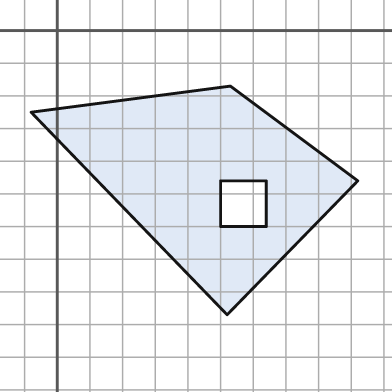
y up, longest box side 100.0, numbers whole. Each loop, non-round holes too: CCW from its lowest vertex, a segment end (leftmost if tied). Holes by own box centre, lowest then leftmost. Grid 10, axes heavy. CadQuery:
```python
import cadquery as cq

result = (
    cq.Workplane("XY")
    .moveTo(52.0, -87.0)
    .lineTo(92.0, -46.0)
    .lineTo(53.0, -17.0)
    .lineTo(-8.0, -25.0)
    .close()
    .moveTo(50.0, -60.0)
    .lineTo(64.0, -60.0)
    .lineTo(64.0, -46.0)
    .lineTo(50.0, -46.0)
    .close()
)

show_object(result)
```